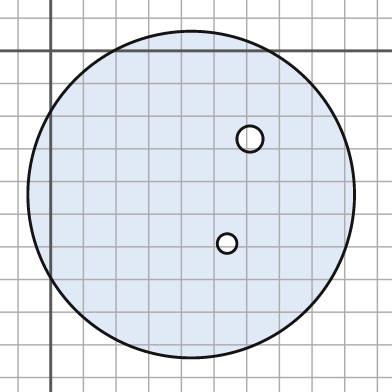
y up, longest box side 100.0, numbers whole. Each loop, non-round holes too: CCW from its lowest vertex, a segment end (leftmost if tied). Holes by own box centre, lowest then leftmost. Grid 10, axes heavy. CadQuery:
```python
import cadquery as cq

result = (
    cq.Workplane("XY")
    .moveTo(43.0, -44.0)
    .circle(50.0)
    .moveTo(54.0, -59.0)
    .circle(3.0)
    .moveTo(61.0, -27.0)
    .circle(4.0)
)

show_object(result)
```